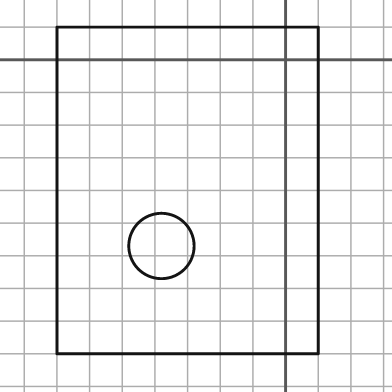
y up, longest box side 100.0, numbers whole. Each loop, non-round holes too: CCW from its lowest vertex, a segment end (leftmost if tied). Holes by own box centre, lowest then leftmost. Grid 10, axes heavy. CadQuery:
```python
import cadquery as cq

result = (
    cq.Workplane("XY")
    .moveTo(-70.0, -90.0)
    .lineTo(10.0, -90.0)
    .lineTo(10.0, 10.0)
    .lineTo(-70.0, 10.0)
    .close()
    .moveTo(-38.0, -57.0)
    .circle(10.0)
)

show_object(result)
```